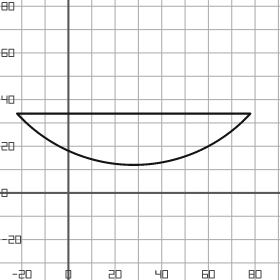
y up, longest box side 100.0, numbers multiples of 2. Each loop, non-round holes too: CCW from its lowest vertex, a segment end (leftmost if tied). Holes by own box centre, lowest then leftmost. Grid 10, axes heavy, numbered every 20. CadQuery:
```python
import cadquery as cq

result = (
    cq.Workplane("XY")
    .moveTo(-22.0, 34.0)
    .threePointArc((28.0, 12.0), (78.0, 34.0))
    .close()
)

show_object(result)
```